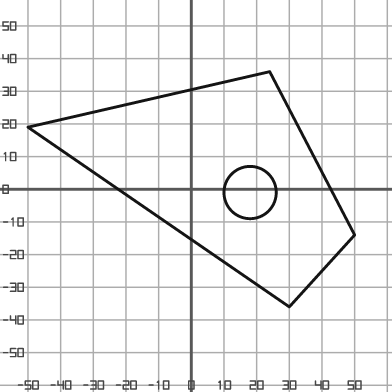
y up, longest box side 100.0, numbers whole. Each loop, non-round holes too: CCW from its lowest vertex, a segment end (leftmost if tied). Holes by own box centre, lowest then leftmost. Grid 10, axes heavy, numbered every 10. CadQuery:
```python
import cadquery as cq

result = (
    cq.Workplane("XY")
    .moveTo(30.0, -36.0)
    .lineTo(50.0, -14.0)
    .lineTo(24.0, 36.0)
    .lineTo(-50.0, 19.0)
    .close()
    .moveTo(18.0, -1.0)
    .circle(8.0)
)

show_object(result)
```